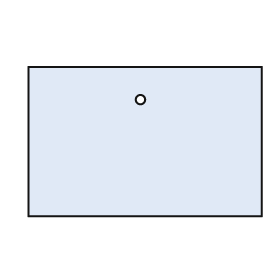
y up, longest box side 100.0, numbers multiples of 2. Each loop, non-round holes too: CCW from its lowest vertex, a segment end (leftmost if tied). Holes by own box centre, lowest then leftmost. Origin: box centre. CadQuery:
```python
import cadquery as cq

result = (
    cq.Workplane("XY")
    .moveTo(-50.0, -32.0)
    .lineTo(50.0, -32.0)
    .lineTo(50.0, 32.0)
    .lineTo(-50.0, 32.0)
    .close()
    .moveTo(-2.0, 18.0)
    .circle(2.0)
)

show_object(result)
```